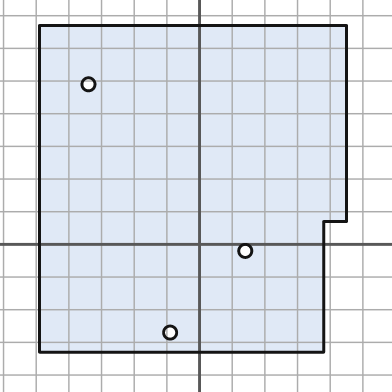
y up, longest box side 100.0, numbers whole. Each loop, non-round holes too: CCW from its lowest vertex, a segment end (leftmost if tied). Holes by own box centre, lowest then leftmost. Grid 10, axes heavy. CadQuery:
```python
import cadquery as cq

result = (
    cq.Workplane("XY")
    .moveTo(-49.0, -33.0)
    .lineTo(38.0, -33.0)
    .lineTo(38.0, 7.0)
    .lineTo(45.0, 7.0)
    .lineTo(45.0, 67.0)
    .lineTo(-49.0, 67.0)
    .close()
    .moveTo(-9.0, -27.0)
    .circle(2.0)
    .moveTo(14.0, -2.0)
    .circle(2.0)
    .moveTo(-34.0, 49.0)
    .circle(2.0)
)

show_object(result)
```